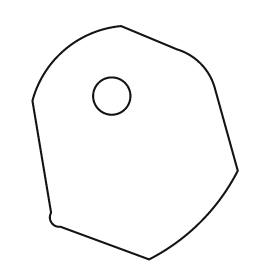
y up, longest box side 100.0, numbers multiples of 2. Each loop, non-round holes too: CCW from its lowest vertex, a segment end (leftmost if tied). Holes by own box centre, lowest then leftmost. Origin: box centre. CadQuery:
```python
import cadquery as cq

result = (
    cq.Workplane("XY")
    .moveTo(6.0, -50.0)
    .threePointArc((28.0, -34.0), (44.0, -12.0))
    .lineTo(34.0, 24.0)
    .threePointArc((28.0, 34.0), (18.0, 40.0))
    .lineTo(-6.0, 50.0)
    .threePointArc((-30.0, 40.0), (-44.0, 18.0))
    .lineTo(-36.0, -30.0)
    .threePointArc((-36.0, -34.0), (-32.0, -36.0))
    .close()
    .moveTo(-10.0, 20.0)
    .circle(8.0)
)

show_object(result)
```